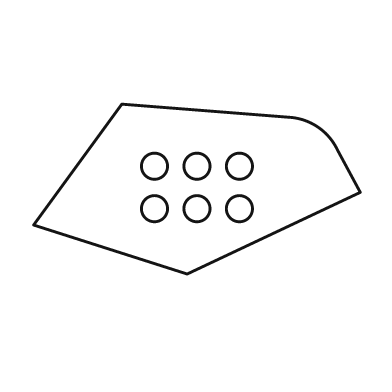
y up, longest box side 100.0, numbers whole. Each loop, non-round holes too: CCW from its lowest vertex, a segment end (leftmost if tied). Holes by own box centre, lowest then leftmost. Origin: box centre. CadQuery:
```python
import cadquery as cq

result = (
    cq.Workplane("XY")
    .moveTo(-3.0, -26.0)
    .lineTo(50.0, -1.0)
    .lineTo(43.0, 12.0)
    .threePointArc((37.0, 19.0), (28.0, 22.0))
    .lineTo(-23.0, 26.0)
    .lineTo(-50.0, -11.0)
    .close()
    .moveTo(-13.0, -6.0)
    .circle(4.0)
    .moveTo(0.0, -6.0)
    .circle(4.0)
    .moveTo(13.0, -6.0)
    .circle(4.0)
    .moveTo(-13.0, 7.0)
    .circle(4.0)
    .moveTo(0.0, 7.0)
    .circle(4.0)
    .moveTo(13.0, 7.0)
    .circle(4.0)
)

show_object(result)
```